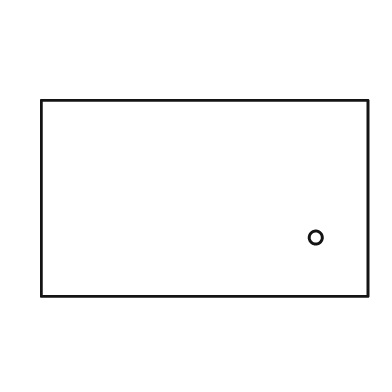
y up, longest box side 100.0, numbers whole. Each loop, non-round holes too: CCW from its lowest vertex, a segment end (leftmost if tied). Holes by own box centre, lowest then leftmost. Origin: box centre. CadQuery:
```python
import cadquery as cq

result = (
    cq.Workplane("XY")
    .moveTo(-50.0, -30.0)
    .lineTo(50.0, -30.0)
    .lineTo(50.0, 30.0)
    .lineTo(-50.0, 30.0)
    .close()
    .moveTo(34.0, -12.0)
    .circle(2.0)
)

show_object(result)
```